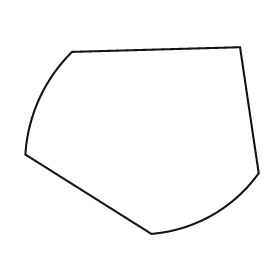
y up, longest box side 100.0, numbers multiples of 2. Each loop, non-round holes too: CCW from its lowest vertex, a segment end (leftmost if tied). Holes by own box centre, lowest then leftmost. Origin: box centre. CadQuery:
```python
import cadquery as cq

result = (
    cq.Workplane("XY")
    .moveTo(4.0, -40.0)
    .threePointArc((30.0, -32.0), (50.0, -14.0))
    .lineTo(42.0, 40.0)
    .lineTo(-30.0, 38.0)
    .threePointArc((-44.0, 18.0), (-50.0, -6.0))
    .close()
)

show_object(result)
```